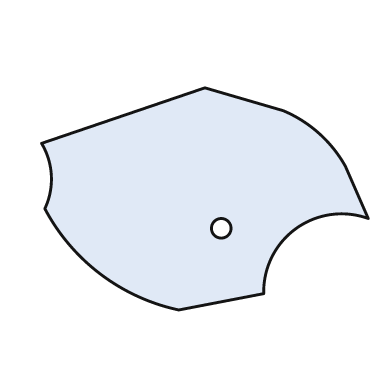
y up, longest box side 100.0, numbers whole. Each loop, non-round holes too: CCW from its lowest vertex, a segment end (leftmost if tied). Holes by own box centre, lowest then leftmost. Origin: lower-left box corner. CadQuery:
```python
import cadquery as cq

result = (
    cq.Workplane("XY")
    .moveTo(42.0, 0.0)
    .lineTo(68.0, 5.0)
    .threePointArc((78.0, 25.0), (100.0, 28.0))
    .lineTo(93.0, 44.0)
    .threePointArc((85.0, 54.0), (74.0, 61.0))
    .lineTo(50.0, 68.0)
    .lineTo(0.0, 51.0)
    .threePointArc((3.0, 41.0), (1.0, 31.0))
    .threePointArc((18.0, 11.0), (42.0, 0.0))
    .close()
    .moveTo(55.0, 25.0)
    .circle(3.0)
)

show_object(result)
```